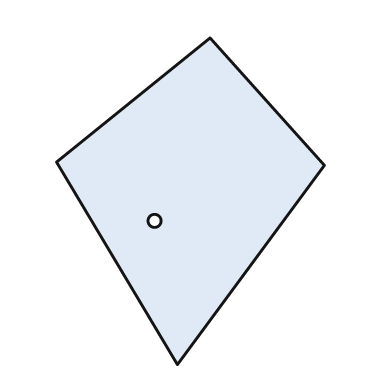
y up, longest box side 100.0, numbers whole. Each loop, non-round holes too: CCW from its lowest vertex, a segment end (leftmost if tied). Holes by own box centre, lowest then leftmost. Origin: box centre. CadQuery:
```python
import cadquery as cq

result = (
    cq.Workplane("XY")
    .moveTo(-4.0, -50.0)
    .lineTo(41.0, 11.0)
    .lineTo(6.0, 50.0)
    .lineTo(-41.0, 12.0)
    .close()
    .moveTo(-11.0, -6.0)
    .circle(2.0)
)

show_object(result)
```